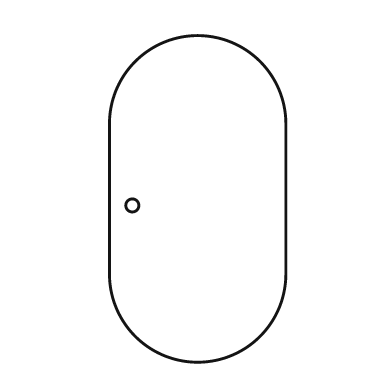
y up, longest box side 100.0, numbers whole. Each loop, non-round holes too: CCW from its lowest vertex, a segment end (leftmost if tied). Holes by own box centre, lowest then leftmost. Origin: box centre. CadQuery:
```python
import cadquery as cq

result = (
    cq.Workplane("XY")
    .moveTo(-27.0, -23.0)
    .threePointArc((0.0, -50.0), (27.0, -23.0))
    .lineTo(27.0, 23.0)
    .threePointArc((0.0, 50.0), (-27.0, 23.0))
    .close()
    .moveTo(-20.0, -2.0)
    .circle(2.0)
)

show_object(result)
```